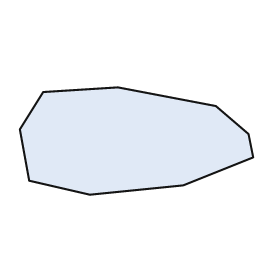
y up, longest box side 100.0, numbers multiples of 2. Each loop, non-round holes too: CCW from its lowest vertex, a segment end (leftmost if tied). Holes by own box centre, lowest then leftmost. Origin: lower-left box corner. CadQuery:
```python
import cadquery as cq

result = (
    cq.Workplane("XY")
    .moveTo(30.0, 0.0)
    .lineTo(70.0, 4.0)
    .lineTo(100.0, 16.0)
    .lineTo(98.0, 26.0)
    .lineTo(84.0, 38.0)
    .lineTo(42.0, 46.0)
    .lineTo(10.0, 44.0)
    .lineTo(0.0, 28.0)
    .lineTo(4.0, 6.0)
    .close()
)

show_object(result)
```